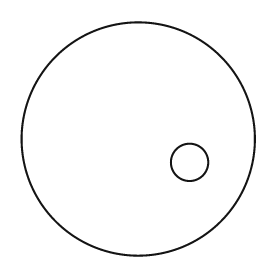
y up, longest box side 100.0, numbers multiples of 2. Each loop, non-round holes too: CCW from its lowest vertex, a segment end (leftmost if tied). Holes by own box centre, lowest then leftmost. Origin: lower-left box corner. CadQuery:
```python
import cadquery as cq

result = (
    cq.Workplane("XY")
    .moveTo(50.0, 50.0)
    .circle(50.0)
    .moveTo(72.0, 40.0)
    .circle(8.0)
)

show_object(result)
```